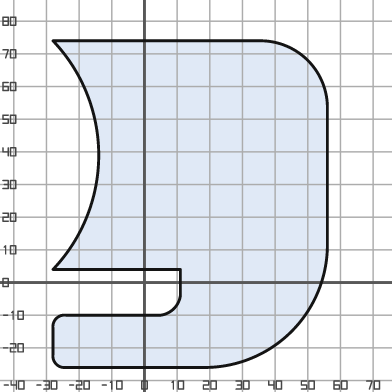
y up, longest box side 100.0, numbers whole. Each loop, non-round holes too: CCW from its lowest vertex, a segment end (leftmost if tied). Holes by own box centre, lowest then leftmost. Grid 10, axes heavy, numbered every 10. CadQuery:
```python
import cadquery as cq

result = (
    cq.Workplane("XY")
    .moveTo(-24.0, -26.0)
    .lineTo(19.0, -26.0)
    .threePointArc((45.0, -15.0), (56.0, 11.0))
    .lineTo(56.0, 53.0)
    .threePointArc((50.0, 68.0), (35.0, 74.0))
    .lineTo(-28.0, 74.0)
    .threePointArc((-14.0, 39.0), (-28.0, 4.0))
    .lineTo(11.0, 4.0)
    .lineTo(11.0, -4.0)
    .threePointArc((9.0, -8.0), (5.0, -10.0))
    .lineTo(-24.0, -10.0)
    .threePointArc((-27.0, -11.0), (-28.0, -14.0))
    .lineTo(-28.0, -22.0)
    .threePointArc((-27.0, -25.0), (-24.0, -26.0))
    .close()
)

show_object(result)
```